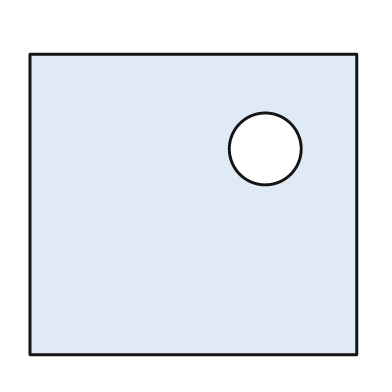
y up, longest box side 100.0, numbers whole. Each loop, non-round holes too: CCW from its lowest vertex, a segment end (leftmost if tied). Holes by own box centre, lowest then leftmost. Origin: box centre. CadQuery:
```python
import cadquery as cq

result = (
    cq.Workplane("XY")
    .moveTo(-50.0, -46.0)
    .lineTo(50.0, -46.0)
    .lineTo(50.0, 46.0)
    .lineTo(-50.0, 46.0)
    .close()
    .moveTo(22.0, 17.0)
    .circle(11.0)
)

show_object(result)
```